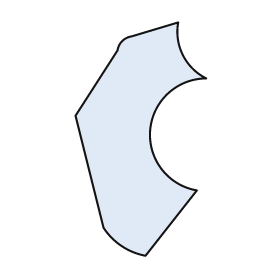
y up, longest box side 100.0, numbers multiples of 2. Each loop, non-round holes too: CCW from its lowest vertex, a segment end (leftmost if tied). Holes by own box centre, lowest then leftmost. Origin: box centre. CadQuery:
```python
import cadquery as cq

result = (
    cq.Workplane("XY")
    .moveTo(2.0, -50.0)
    .lineTo(24.0, -22.0)
    .threePointArc((4.0, 4.0), (28.0, 26.0))
    .threePointArc((18.0, 36.0), (16.0, 50.0))
    .lineTo(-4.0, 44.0)
    .threePointArc((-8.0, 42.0), (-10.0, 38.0))
    .lineTo(-28.0, 10.0)
    .lineTo(-16.0, -38.0)
    .threePointArc((-8.0, -46.0), (2.0, -50.0))
    .close()
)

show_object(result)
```